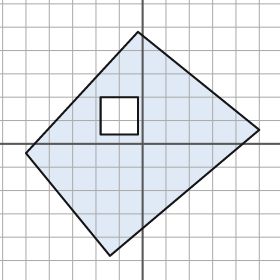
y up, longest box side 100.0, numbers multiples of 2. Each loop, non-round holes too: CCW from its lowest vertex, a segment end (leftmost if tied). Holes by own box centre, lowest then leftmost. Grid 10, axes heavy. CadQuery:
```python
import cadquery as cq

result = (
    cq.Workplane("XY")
    .moveTo(-14.0, -48.0)
    .lineTo(50.0, 6.0)
    .lineTo(-2.0, 48.0)
    .lineTo(-50.0, -4.0)
    .close()
    .moveTo(-18.0, 4.0)
    .lineTo(-2.0, 4.0)
    .lineTo(-2.0, 20.0)
    .lineTo(-18.0, 20.0)
    .close()
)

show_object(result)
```